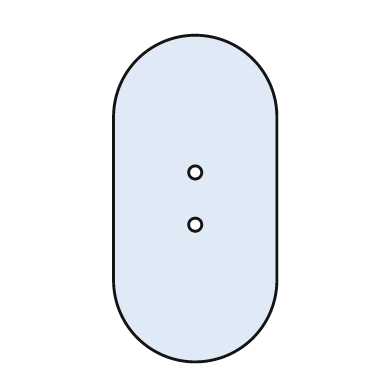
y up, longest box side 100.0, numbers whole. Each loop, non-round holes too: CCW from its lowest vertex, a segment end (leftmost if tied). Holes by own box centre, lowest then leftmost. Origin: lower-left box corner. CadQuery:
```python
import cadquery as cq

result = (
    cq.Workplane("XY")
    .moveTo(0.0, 25.0)
    .threePointArc((25.0, 0.0), (50.0, 25.0))
    .lineTo(50.0, 75.0)
    .threePointArc((25.0, 100.0), (0.0, 75.0))
    .close()
    .moveTo(25.0, 42.0)
    .circle(2.0)
    .moveTo(25.0, 58.0)
    .circle(2.0)
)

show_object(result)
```